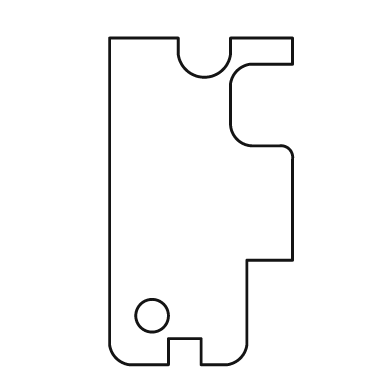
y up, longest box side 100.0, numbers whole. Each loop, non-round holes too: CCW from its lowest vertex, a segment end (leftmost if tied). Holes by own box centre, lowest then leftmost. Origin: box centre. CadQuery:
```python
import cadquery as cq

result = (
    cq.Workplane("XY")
    .moveTo(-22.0, -50.0)
    .lineTo(-10.0, -50.0)
    .lineTo(-10.0, -42.0)
    .lineTo(0.0, -42.0)
    .lineTo(0.0, -50.0)
    .lineTo(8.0, -50.0)
    .threePointArc((12.0, -48.0), (14.0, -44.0))
    .lineTo(14.0, -18.0)
    .lineTo(28.0, -18.0)
    .lineTo(28.0, 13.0)
    .threePointArc((27.0, 16.0), (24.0, 17.0))
    .lineTo(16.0, 17.0)
    .threePointArc((11.0, 19.0), (9.0, 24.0))
    .lineTo(9.0, 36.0)
    .threePointArc((11.0, 40.0), (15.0, 42.0))
    .lineTo(28.0, 42.0)
    .lineTo(28.0, 50.0)
    .lineTo(9.0, 50.0)
    .lineTo(9.0, 45.0)
    .threePointArc((1.0, 38.0), (-7.0, 45.0))
    .lineTo(-7.0, 50.0)
    .lineTo(-28.0, 50.0)
    .lineTo(-28.0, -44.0)
    .threePointArc((-26.0, -48.0), (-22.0, -50.0))
    .close()
    .moveTo(-15.0, -35.0)
    .circle(5.0)
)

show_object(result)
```